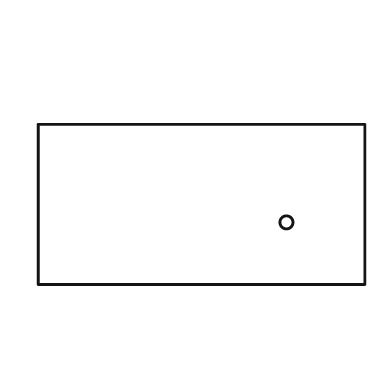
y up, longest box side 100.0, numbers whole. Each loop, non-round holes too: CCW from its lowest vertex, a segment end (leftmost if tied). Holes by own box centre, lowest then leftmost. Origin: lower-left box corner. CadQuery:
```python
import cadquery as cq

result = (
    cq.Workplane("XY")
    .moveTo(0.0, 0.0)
    .lineTo(100.0, 0.0)
    .lineTo(100.0, 49.0)
    .lineTo(0.0, 49.0)
    .close()
    .moveTo(76.0, 19.0)
    .circle(2.0)
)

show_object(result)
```